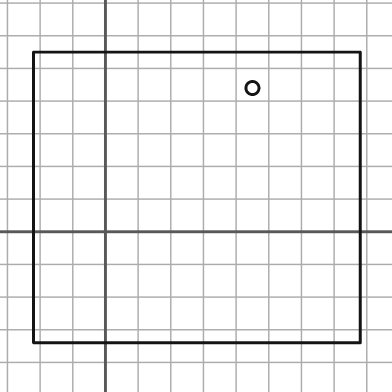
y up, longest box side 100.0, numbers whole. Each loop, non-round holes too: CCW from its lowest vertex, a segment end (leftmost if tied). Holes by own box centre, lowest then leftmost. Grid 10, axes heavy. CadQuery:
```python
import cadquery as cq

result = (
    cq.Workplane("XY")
    .moveTo(-22.0, -34.0)
    .lineTo(78.0, -34.0)
    .lineTo(78.0, 55.0)
    .lineTo(-22.0, 55.0)
    .close()
    .moveTo(45.0, 44.0)
    .circle(2.0)
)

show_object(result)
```